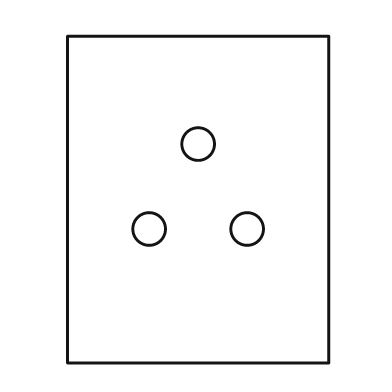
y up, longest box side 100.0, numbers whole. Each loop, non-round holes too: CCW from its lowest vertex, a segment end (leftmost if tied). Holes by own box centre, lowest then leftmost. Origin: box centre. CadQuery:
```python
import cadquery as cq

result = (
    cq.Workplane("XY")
    .moveTo(-40.0, -50.0)
    .lineTo(40.0, -50.0)
    .lineTo(40.0, 50.0)
    .lineTo(-40.0, 50.0)
    .close()
    .moveTo(-15.0, -9.0)
    .circle(5.0)
    .moveTo(15.0, -9.0)
    .circle(5.0)
    .moveTo(0.0, 17.0)
    .circle(5.0)
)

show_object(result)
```